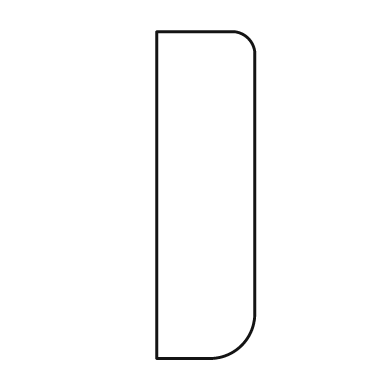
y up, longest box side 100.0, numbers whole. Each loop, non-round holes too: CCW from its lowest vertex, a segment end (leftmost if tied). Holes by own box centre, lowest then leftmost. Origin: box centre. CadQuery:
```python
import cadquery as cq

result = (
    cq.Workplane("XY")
    .moveTo(-15.0, -50.0)
    .lineTo(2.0, -50.0)
    .threePointArc((11.0, -46.0), (15.0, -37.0))
    .lineTo(15.0, 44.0)
    .threePointArc((13.0, 48.0), (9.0, 50.0))
    .lineTo(-15.0, 50.0)
    .close()
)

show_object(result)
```